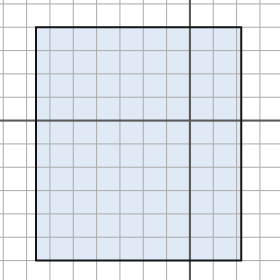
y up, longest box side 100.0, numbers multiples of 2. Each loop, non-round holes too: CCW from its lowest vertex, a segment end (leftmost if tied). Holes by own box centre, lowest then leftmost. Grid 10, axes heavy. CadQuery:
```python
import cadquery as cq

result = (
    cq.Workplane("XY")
    .moveTo(-66.0, -60.0)
    .lineTo(22.0, -60.0)
    .lineTo(22.0, 40.0)
    .lineTo(-66.0, 40.0)
    .close()
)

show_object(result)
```